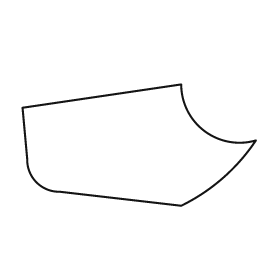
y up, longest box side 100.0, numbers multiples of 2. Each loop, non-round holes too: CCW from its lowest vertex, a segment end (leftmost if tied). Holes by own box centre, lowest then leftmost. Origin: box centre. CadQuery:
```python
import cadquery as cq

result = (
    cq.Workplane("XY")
    .moveTo(18.0, -26.0)
    .threePointArc((36.0, -14.0), (50.0, 2.0))
    .threePointArc((28.0, 6.0), (18.0, 26.0))
    .lineTo(-50.0, 16.0)
    .lineTo(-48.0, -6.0)
    .threePointArc((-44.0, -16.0), (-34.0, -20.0))
    .close()
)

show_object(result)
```